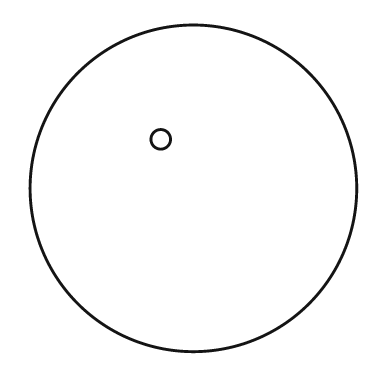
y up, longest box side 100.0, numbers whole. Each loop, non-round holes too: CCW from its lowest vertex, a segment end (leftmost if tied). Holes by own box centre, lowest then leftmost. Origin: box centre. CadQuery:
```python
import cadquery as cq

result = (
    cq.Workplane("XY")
    .moveTo(0.0, 0.0)
    .circle(50.0)
    .moveTo(-10.0, 15.0)
    .circle(3.0)
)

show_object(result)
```